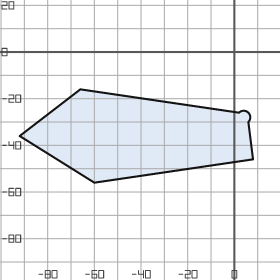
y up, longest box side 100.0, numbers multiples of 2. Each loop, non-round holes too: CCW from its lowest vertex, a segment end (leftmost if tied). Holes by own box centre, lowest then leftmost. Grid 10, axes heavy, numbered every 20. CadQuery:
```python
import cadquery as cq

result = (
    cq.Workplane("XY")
    .moveTo(-60.0, -56.0)
    .lineTo(8.0, -46.0)
    .lineTo(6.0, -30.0)
    .threePointArc((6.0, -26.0), (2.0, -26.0))
    .lineTo(-66.0, -16.0)
    .lineTo(-92.0, -36.0)
    .close()
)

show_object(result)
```